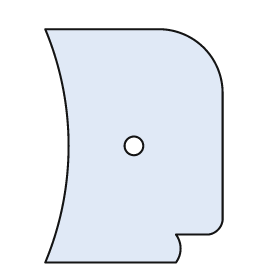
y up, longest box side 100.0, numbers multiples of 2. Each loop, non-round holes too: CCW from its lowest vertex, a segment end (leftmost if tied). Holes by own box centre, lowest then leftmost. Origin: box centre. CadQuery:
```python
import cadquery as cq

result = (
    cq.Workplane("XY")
    .moveTo(-38.0, -50.0)
    .lineTo(18.0, -50.0)
    .threePointArc((20.0, -44.0), (18.0, -38.0))
    .lineTo(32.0, -38.0)
    .threePointArc((36.0, -36.0), (38.0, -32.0))
    .lineTo(38.0, 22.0)
    .threePointArc((30.0, 42.0), (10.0, 50.0))
    .lineTo(-38.0, 50.0)
    .threePointArc((-28.0, 0.0), (-38.0, -50.0))
    .close()
    .moveTo(0.0, 0.0)
    .circle(4.0)
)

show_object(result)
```